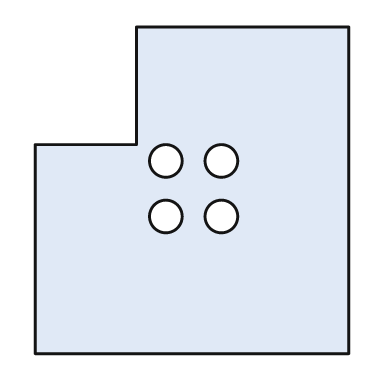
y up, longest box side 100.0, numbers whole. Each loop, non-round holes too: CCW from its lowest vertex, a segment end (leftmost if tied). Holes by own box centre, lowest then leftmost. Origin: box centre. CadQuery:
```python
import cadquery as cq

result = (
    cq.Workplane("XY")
    .moveTo(-48.0, -50.0)
    .lineTo(48.0, -50.0)
    .lineTo(48.0, 50.0)
    .lineTo(-17.0, 50.0)
    .lineTo(-17.0, 14.0)
    .lineTo(-48.0, 14.0)
    .close()
    .moveTo(-8.0, -8.0)
    .circle(5.0)
    .moveTo(9.0, -8.0)
    .circle(5.0)
    .moveTo(-8.0, 9.0)
    .circle(5.0)
    .moveTo(9.0, 9.0)
    .circle(5.0)
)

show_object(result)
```